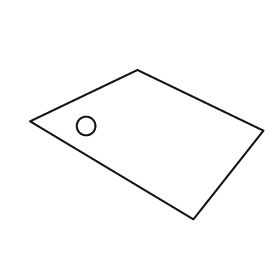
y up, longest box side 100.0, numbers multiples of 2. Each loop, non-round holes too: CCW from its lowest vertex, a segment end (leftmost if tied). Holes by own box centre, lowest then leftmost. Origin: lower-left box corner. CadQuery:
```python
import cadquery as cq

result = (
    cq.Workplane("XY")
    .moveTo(70.0, 0.0)
    .lineTo(100.0, 38.0)
    .lineTo(46.0, 64.0)
    .lineTo(0.0, 42.0)
    .close()
    .moveTo(24.0, 40.0)
    .circle(4.0)
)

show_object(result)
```